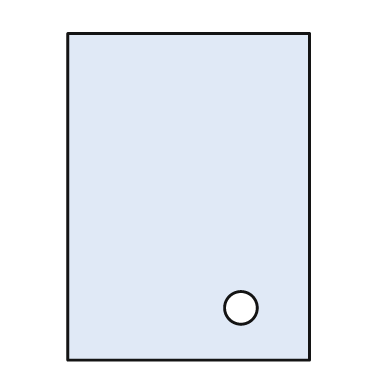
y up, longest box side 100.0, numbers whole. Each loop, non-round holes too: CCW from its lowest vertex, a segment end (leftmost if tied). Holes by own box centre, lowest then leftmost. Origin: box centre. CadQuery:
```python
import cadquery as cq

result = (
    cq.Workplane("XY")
    .moveTo(-37.0, -50.0)
    .lineTo(37.0, -50.0)
    .lineTo(37.0, 50.0)
    .lineTo(-37.0, 50.0)
    .close()
    .moveTo(16.0, -34.0)
    .circle(5.0)
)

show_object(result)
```